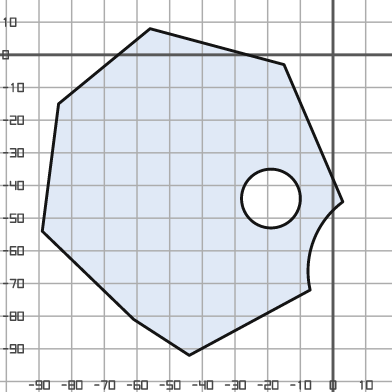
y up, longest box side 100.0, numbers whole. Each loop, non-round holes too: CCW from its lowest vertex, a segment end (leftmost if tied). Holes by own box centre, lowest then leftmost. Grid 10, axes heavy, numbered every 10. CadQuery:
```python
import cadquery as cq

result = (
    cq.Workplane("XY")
    .moveTo(-44.0, -92.0)
    .lineTo(-7.0, -72.0)
    .threePointArc((-6.0, -57.0), (3.0, -45.0))
    .lineTo(-15.0, -3.0)
    .lineTo(-56.0, 8.0)
    .lineTo(-84.0, -15.0)
    .lineTo(-89.0, -54.0)
    .lineTo(-61.0, -81.0)
    .close()
    .moveTo(-19.0, -44.0)
    .circle(9.0)
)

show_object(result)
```